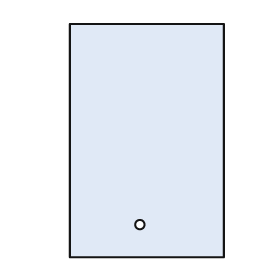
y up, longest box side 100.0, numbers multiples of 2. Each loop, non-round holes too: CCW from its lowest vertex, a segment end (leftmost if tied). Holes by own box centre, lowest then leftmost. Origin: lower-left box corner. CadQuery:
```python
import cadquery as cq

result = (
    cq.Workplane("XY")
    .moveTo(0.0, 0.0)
    .lineTo(66.0, 0.0)
    .lineTo(66.0, 100.0)
    .lineTo(0.0, 100.0)
    .close()
    .moveTo(30.0, 14.0)
    .circle(2.0)
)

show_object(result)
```